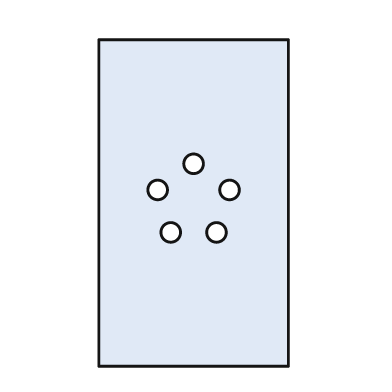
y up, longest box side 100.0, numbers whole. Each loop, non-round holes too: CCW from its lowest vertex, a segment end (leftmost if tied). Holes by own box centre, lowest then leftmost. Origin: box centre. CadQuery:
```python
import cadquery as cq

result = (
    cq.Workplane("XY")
    .moveTo(-29.0, -50.0)
    .lineTo(29.0, -50.0)
    .lineTo(29.0, 50.0)
    .lineTo(-29.0, 50.0)
    .close()
    .moveTo(-7.0, -9.0)
    .circle(3.0)
    .moveTo(7.0, -9.0)
    .circle(3.0)
    .moveTo(-11.0, 4.0)
    .circle(3.0)
    .moveTo(11.0, 4.0)
    .circle(3.0)
    .moveTo(0.0, 12.0)
    .circle(3.0)
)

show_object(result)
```